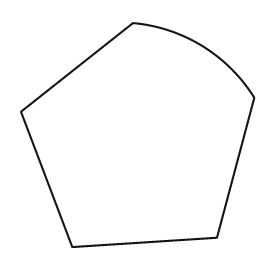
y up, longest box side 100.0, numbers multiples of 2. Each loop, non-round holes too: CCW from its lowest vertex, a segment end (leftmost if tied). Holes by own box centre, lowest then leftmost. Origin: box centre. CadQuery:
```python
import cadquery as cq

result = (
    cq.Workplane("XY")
    .moveTo(-28.0, -48.0)
    .lineTo(34.0, -44.0)
    .lineTo(50.0, 16.0)
    .threePointArc((28.0, 38.0), (-2.0, 48.0))
    .lineTo(-50.0, 10.0)
    .close()
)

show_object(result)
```